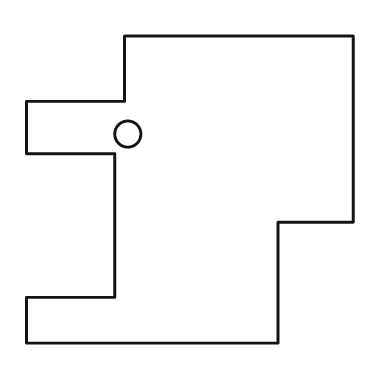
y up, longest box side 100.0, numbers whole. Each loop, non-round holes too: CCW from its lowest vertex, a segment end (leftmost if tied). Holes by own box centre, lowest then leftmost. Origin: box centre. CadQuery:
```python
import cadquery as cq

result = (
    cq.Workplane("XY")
    .moveTo(-50.0, -47.0)
    .lineTo(27.0, -47.0)
    .lineTo(27.0, -10.0)
    .lineTo(50.0, -10.0)
    .lineTo(50.0, 47.0)
    .lineTo(-20.0, 47.0)
    .lineTo(-20.0, 27.0)
    .lineTo(-50.0, 27.0)
    .lineTo(-50.0, 11.0)
    .lineTo(-23.0, 11.0)
    .lineTo(-23.0, -33.0)
    .lineTo(-50.0, -33.0)
    .close()
    .moveTo(-19.0, 17.0)
    .circle(4.0)
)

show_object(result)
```